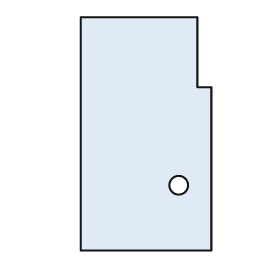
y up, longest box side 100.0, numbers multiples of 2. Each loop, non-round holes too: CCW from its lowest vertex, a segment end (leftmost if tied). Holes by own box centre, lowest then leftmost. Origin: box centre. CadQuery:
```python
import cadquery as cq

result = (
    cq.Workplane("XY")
    .moveTo(-28.0, -50.0)
    .lineTo(28.0, -50.0)
    .lineTo(28.0, 20.0)
    .lineTo(22.0, 20.0)
    .lineTo(22.0, 50.0)
    .lineTo(-28.0, 50.0)
    .close()
    .moveTo(14.0, -22.0)
    .circle(4.0)
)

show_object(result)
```